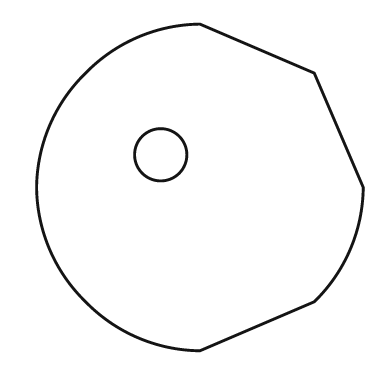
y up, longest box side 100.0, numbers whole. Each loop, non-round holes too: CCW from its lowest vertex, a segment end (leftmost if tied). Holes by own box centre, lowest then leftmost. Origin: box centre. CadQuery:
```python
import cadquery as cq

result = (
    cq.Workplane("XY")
    .moveTo(0.0, -50.0)
    .lineTo(35.0, -35.0)
    .threePointArc((46.0, -19.0), (50.0, 0.0))
    .lineTo(35.0, 35.0)
    .lineTo(0.0, 50.0)
    .threePointArc((-19.0, 46.0), (-35.0, 35.0))
    .threePointArc((-46.0, 19.0), (-50.0, 0.0))
    .threePointArc((-46.0, -19.0), (-35.0, -35.0))
    .threePointArc((-19.0, -46.0), (0.0, -50.0))
    .close()
    .moveTo(-12.0, 10.0)
    .circle(8.0)
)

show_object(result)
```